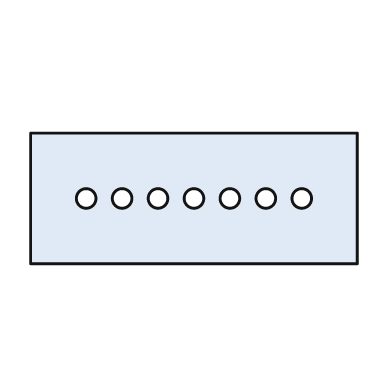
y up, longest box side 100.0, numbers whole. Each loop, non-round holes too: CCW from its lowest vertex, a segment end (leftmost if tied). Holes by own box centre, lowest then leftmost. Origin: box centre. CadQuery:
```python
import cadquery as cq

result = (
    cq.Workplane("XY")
    .moveTo(-50.0, -20.0)
    .lineTo(50.0, -20.0)
    .lineTo(50.0, 20.0)
    .lineTo(-50.0, 20.0)
    .close()
    .moveTo(-33.0, 0.0)
    .circle(3.0)
    .moveTo(-22.0, 0.0)
    .circle(3.0)
    .moveTo(-11.0, 0.0)
    .circle(3.0)
    .moveTo(0.0, 0.0)
    .circle(3.0)
    .moveTo(11.0, 0.0)
    .circle(3.0)
    .moveTo(22.0, 0.0)
    .circle(3.0)
    .moveTo(33.0, 0.0)
    .circle(3.0)
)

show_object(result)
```